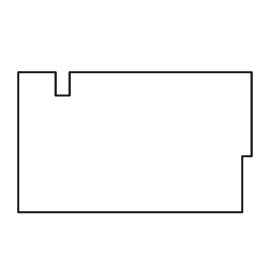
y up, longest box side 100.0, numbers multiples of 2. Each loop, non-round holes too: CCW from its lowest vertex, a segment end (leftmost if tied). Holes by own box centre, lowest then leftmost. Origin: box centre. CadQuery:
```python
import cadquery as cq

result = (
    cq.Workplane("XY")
    .moveTo(-50.0, -30.0)
    .lineTo(46.0, -30.0)
    .lineTo(46.0, -6.0)
    .lineTo(50.0, -6.0)
    .lineTo(50.0, 30.0)
    .lineTo(-28.0, 30.0)
    .lineTo(-28.0, 20.0)
    .lineTo(-34.0, 20.0)
    .lineTo(-34.0, 30.0)
    .lineTo(-50.0, 30.0)
    .close()
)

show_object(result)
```